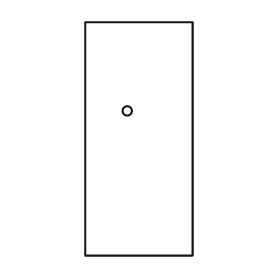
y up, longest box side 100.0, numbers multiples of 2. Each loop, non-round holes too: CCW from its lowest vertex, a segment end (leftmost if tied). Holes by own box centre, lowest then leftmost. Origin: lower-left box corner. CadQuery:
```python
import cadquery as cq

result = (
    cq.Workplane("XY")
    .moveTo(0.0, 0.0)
    .lineTo(46.0, 0.0)
    .lineTo(46.0, 100.0)
    .lineTo(0.0, 100.0)
    .close()
    .moveTo(18.0, 62.0)
    .circle(2.0)
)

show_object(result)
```